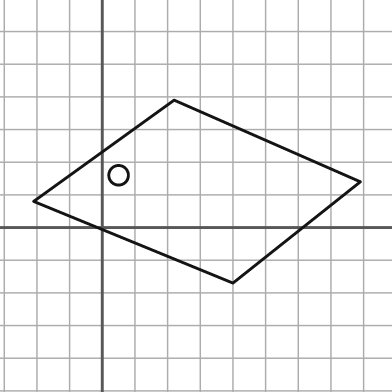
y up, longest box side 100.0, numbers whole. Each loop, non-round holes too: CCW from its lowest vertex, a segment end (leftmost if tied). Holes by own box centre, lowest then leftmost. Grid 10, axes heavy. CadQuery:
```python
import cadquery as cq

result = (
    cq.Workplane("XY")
    .moveTo(40.0, -17.0)
    .lineTo(79.0, 14.0)
    .lineTo(22.0, 39.0)
    .lineTo(-21.0, 8.0)
    .close()
    .moveTo(5.0, 16.0)
    .circle(3.0)
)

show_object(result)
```